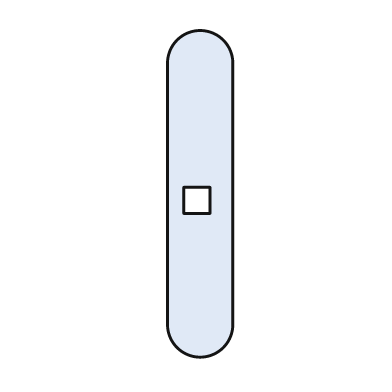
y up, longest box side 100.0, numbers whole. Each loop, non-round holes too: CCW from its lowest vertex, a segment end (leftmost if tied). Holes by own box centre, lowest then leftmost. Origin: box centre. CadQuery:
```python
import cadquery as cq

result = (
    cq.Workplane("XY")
    .moveTo(-10.0, -40.0)
    .threePointArc((0.0, -50.0), (10.0, -40.0))
    .lineTo(10.0, 40.0)
    .threePointArc((0.0, 50.0), (-10.0, 40.0))
    .close()
    .moveTo(-5.0, -6.0)
    .lineTo(3.0, -6.0)
    .lineTo(3.0, 2.0)
    .lineTo(-5.0, 2.0)
    .close()
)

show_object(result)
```